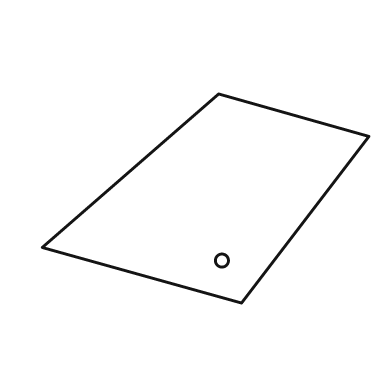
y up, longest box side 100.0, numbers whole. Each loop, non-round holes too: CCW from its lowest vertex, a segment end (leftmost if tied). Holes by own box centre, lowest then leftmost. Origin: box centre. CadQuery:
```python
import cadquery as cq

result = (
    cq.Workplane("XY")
    .moveTo(11.0, -32.0)
    .lineTo(50.0, 19.0)
    .lineTo(4.0, 32.0)
    .lineTo(-50.0, -15.0)
    .close()
    .moveTo(5.0, -19.0)
    .circle(2.0)
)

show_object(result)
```